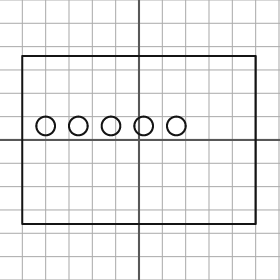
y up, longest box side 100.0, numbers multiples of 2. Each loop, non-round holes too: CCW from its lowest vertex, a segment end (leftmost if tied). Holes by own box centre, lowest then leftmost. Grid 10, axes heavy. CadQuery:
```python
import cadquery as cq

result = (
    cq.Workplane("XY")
    .moveTo(-50.0, -36.0)
    .lineTo(50.0, -36.0)
    .lineTo(50.0, 36.0)
    .lineTo(-50.0, 36.0)
    .close()
    .moveTo(-40.0, 6.0)
    .circle(4.0)
    .moveTo(-26.0, 6.0)
    .circle(4.0)
    .moveTo(-12.0, 6.0)
    .circle(4.0)
    .moveTo(2.0, 6.0)
    .circle(4.0)
    .moveTo(16.0, 6.0)
    .circle(4.0)
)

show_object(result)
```